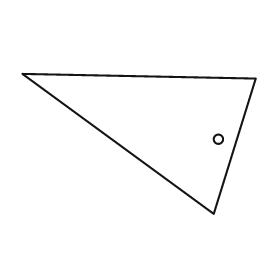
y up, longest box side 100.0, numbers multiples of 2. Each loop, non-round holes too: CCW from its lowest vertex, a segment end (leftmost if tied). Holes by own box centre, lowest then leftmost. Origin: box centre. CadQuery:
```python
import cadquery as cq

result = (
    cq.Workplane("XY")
    .moveTo(32.0, -30.0)
    .lineTo(50.0, 28.0)
    .lineTo(-50.0, 30.0)
    .close()
    .moveTo(34.0, 2.0)
    .circle(2.0)
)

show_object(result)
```